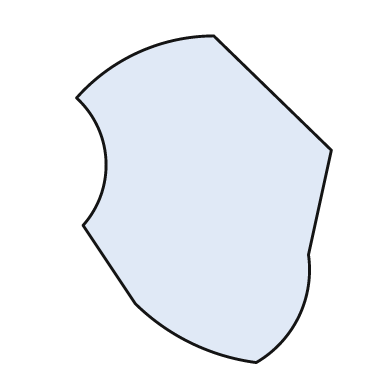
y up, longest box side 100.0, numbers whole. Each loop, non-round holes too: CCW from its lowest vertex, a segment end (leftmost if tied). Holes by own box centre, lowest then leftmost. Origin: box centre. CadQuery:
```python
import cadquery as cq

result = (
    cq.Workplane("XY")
    .moveTo(16.0, -50.0)
    .threePointArc((29.0, -36.0), (32.0, -17.0))
    .lineTo(39.0, 15.0)
    .lineTo(3.0, 50.0)
    .threePointArc((-20.0, 45.0), (-39.0, 31.0))
    .threePointArc((-30.0, 12.0), (-37.0, -8.0))
    .lineTo(-21.0, -32.0)
    .threePointArc((-4.0, -44.0), (16.0, -50.0))
    .close()
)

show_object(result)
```